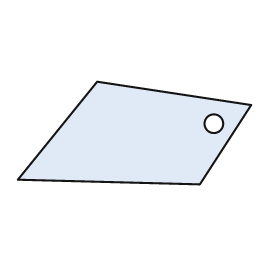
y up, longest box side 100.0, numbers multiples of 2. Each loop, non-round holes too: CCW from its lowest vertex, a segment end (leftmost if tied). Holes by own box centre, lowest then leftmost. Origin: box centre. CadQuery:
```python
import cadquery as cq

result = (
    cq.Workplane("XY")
    .moveTo(28.0, -22.0)
    .lineTo(50.0, 12.0)
    .lineTo(-16.0, 22.0)
    .lineTo(-50.0, -20.0)
    .close()
    .moveTo(34.0, 4.0)
    .circle(4.0)
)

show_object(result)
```